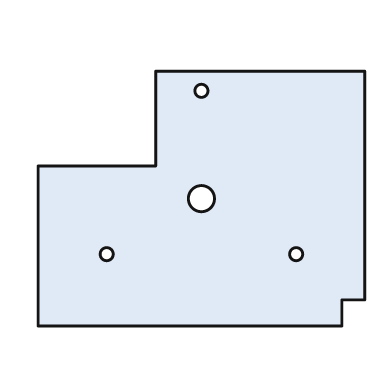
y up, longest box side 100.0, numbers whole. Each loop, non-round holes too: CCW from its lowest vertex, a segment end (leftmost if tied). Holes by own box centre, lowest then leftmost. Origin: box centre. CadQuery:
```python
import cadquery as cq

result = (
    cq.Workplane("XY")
    .moveTo(-50.0, -39.0)
    .lineTo(43.0, -39.0)
    .lineTo(43.0, -31.0)
    .lineTo(50.0, -31.0)
    .lineTo(50.0, 39.0)
    .lineTo(-14.0, 39.0)
    .lineTo(-14.0, 10.0)
    .lineTo(-50.0, 10.0)
    .close()
    .moveTo(-29.0, -17.0)
    .circle(2.0)
    .moveTo(29.0, -17.0)
    .circle(2.0)
    .moveTo(0.0, 0.0)
    .circle(4.0)
    .moveTo(0.0, 33.0)
    .circle(2.0)
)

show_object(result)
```